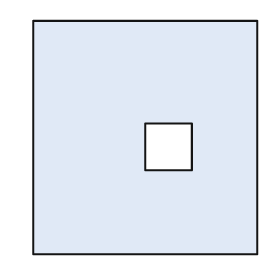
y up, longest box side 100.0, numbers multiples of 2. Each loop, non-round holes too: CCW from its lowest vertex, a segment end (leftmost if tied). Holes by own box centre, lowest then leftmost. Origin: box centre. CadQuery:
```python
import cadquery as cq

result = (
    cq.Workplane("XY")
    .moveTo(-48.0, -50.0)
    .lineTo(48.0, -50.0)
    .lineTo(48.0, 50.0)
    .lineTo(-48.0, 50.0)
    .close()
    .moveTo(0.0, -14.0)
    .lineTo(20.0, -14.0)
    .lineTo(20.0, 6.0)
    .lineTo(0.0, 6.0)
    .close()
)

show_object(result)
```